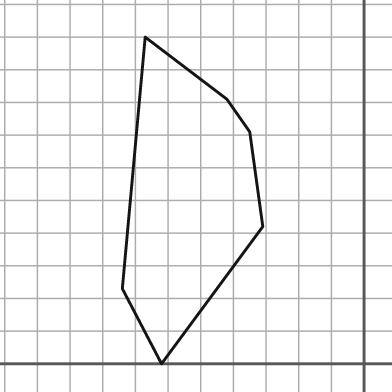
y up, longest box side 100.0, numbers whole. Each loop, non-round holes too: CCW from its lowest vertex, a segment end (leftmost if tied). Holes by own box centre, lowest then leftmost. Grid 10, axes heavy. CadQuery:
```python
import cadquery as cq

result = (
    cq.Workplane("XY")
    .moveTo(-62.0, 0.0)
    .lineTo(-31.0, 42.0)
    .lineTo(-35.0, 71.0)
    .lineTo(-42.0, 81.0)
    .lineTo(-67.0, 100.0)
    .lineTo(-74.0, 23.0)
    .close()
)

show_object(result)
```